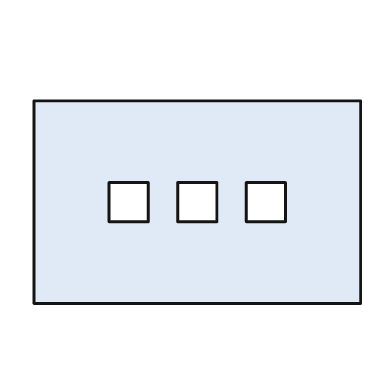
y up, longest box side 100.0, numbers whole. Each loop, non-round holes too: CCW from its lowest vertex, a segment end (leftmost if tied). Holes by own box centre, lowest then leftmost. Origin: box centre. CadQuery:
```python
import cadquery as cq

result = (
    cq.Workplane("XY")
    .moveTo(-50.0, -31.0)
    .lineTo(50.0, -31.0)
    .lineTo(50.0, 31.0)
    .lineTo(-50.0, 31.0)
    .close()
    .moveTo(-27.0, -6.0)
    .lineTo(-15.0, -6.0)
    .lineTo(-15.0, 6.0)
    .lineTo(-27.0, 6.0)
    .close()
    .moveTo(-6.0, -6.0)
    .lineTo(6.0, -6.0)
    .lineTo(6.0, 6.0)
    .lineTo(-6.0, 6.0)
    .close()
    .moveTo(15.0, -6.0)
    .lineTo(27.0, -6.0)
    .lineTo(27.0, 6.0)
    .lineTo(15.0, 6.0)
    .close()
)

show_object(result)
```